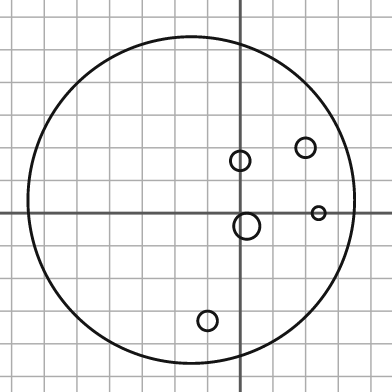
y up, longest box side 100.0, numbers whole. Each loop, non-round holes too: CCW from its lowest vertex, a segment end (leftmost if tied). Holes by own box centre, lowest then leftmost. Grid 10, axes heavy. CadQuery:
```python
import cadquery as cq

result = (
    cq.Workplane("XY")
    .moveTo(-15.0, 4.0)
    .circle(50.0)
    .moveTo(-10.0, -33.0)
    .circle(3.0)
    .moveTo(2.0, -4.0)
    .circle(4.0)
    .moveTo(24.0, 0.0)
    .circle(2.0)
    .moveTo(0.0, 16.0)
    .circle(3.0)
    .moveTo(20.0, 20.0)
    .circle(3.0)
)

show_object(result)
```